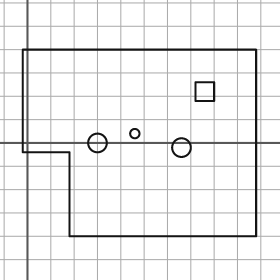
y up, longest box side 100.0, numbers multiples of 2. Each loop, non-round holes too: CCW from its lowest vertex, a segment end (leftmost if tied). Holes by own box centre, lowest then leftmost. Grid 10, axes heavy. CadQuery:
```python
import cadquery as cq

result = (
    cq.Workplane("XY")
    .moveTo(18.0, -40.0)
    .lineTo(98.0, -40.0)
    .lineTo(98.0, 40.0)
    .lineTo(-2.0, 40.0)
    .lineTo(-2.0, -4.0)
    .lineTo(18.0, -4.0)
    .close()
    .moveTo(66.0, -2.0)
    .circle(4.0)
    .moveTo(30.0, 0.0)
    .circle(4.0)
    .moveTo(46.0, 4.0)
    .circle(2.0)
    .moveTo(72.0, 18.0)
    .lineTo(80.0, 18.0)
    .lineTo(80.0, 26.0)
    .lineTo(72.0, 26.0)
    .close()
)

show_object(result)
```